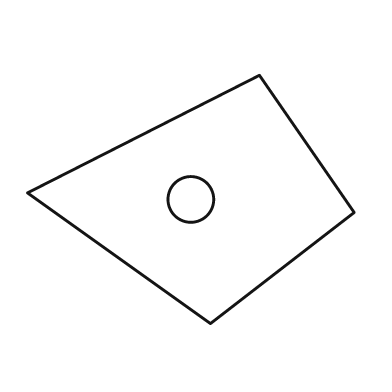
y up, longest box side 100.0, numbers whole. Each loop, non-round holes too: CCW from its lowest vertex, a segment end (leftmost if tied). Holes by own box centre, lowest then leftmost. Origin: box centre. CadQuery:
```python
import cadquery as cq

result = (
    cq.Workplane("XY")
    .moveTo(6.0, -38.0)
    .lineTo(50.0, -4.0)
    .lineTo(21.0, 38.0)
    .lineTo(-50.0, 2.0)
    .close()
    .moveTo(0.0, 0.0)
    .circle(7.0)
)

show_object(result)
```